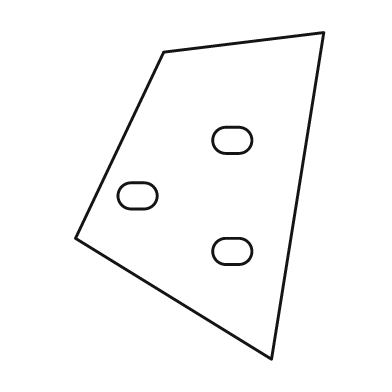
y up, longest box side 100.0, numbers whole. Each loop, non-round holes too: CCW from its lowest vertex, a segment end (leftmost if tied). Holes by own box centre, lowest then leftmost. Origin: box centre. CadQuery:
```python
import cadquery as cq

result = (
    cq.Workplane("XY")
    .moveTo(22.0, -50.0)
    .lineTo(38.0, 50.0)
    .lineTo(-11.0, 44.0)
    .lineTo(-38.0, -13.0)
    .close()
    .moveTo(8.0, -21.0)
    .lineTo(12.0, -21.0)
    .threePointArc((16.0, -17.0), (12.0, -13.0))
    .lineTo(8.0, -13.0)
    .threePointArc((4.0, -17.0), (8.0, -21.0))
    .close()
    .moveTo(-21.0, -4.0)
    .lineTo(-17.0, -4.0)
    .threePointArc((-13.0, 0.0), (-17.0, 4.0))
    .lineTo(-21.0, 4.0)
    .threePointArc((-25.0, 0.0), (-21.0, -4.0))
    .close()
    .moveTo(8.0, 13.0)
    .lineTo(12.0, 13.0)
    .threePointArc((16.0, 17.0), (12.0, 21.0))
    .lineTo(8.0, 21.0)
    .threePointArc((4.0, 17.0), (8.0, 13.0))
    .close()
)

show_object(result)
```